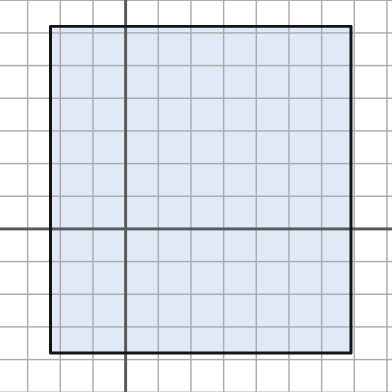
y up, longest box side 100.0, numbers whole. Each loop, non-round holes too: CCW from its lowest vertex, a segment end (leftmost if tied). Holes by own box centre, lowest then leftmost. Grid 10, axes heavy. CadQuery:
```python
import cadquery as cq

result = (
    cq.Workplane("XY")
    .moveTo(-23.0, -38.0)
    .lineTo(69.0, -38.0)
    .lineTo(69.0, 62.0)
    .lineTo(-23.0, 62.0)
    .close()
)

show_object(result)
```